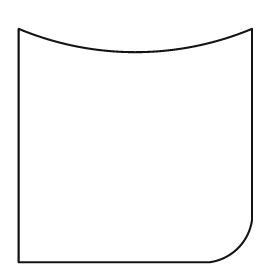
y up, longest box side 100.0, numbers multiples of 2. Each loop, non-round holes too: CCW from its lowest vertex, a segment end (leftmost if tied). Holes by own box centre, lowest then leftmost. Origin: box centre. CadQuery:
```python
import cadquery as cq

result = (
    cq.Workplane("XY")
    .moveTo(-50.0, -50.0)
    .lineTo(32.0, -50.0)
    .threePointArc((44.0, -44.0), (50.0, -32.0))
    .lineTo(50.0, 50.0)
    .threePointArc((0.0, 40.0), (-50.0, 50.0))
    .close()
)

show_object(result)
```